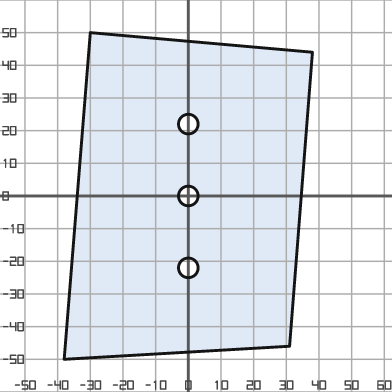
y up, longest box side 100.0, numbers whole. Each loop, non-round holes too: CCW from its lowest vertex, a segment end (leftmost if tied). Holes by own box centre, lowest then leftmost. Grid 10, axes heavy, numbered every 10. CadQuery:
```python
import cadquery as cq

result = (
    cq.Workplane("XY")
    .moveTo(-38.0, -50.0)
    .lineTo(31.0, -46.0)
    .lineTo(38.0, 44.0)
    .lineTo(-30.0, 50.0)
    .close()
    .moveTo(0.0, -22.0)
    .circle(3.0)
    .moveTo(0.0, 0.0)
    .circle(3.0)
    .moveTo(0.0, 22.0)
    .circle(3.0)
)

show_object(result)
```